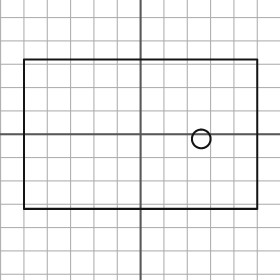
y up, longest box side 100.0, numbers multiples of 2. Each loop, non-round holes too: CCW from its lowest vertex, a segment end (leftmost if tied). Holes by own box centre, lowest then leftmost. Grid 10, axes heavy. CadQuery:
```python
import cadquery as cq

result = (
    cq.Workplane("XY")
    .moveTo(-50.0, -32.0)
    .lineTo(50.0, -32.0)
    .lineTo(50.0, 32.0)
    .lineTo(-50.0, 32.0)
    .close()
    .moveTo(26.0, -2.0)
    .circle(4.0)
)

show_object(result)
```